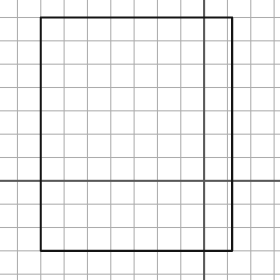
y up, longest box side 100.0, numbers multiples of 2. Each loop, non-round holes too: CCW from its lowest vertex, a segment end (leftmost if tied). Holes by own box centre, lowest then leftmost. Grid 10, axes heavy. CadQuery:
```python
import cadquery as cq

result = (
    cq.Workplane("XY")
    .moveTo(-70.0, -30.0)
    .lineTo(12.0, -30.0)
    .lineTo(12.0, 70.0)
    .lineTo(-70.0, 70.0)
    .close()
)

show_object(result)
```